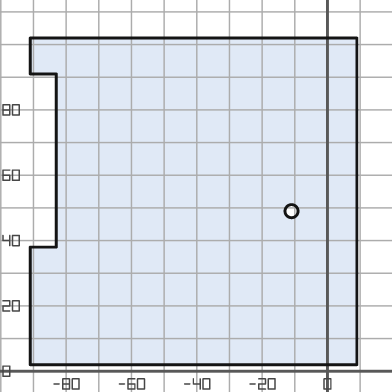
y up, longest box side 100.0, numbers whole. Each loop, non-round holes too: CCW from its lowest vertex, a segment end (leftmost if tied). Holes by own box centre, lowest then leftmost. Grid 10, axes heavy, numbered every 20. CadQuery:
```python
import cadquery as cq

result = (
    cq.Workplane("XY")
    .moveTo(-91.0, 2.0)
    .lineTo(9.0, 2.0)
    .lineTo(9.0, 102.0)
    .lineTo(-91.0, 102.0)
    .lineTo(-91.0, 91.0)
    .lineTo(-83.0, 91.0)
    .lineTo(-83.0, 38.0)
    .lineTo(-91.0, 38.0)
    .close()
    .moveTo(-11.0, 49.0)
    .circle(2.0)
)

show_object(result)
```